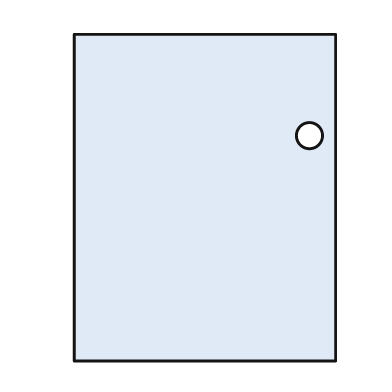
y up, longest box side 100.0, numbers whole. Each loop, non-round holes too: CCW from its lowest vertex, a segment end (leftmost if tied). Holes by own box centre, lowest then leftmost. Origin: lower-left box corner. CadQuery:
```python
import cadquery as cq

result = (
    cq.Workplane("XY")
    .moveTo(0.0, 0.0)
    .lineTo(80.0, 0.0)
    .lineTo(80.0, 100.0)
    .lineTo(0.0, 100.0)
    .close()
    .moveTo(72.0, 69.0)
    .circle(4.0)
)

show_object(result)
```